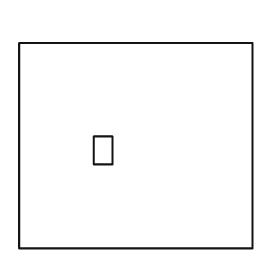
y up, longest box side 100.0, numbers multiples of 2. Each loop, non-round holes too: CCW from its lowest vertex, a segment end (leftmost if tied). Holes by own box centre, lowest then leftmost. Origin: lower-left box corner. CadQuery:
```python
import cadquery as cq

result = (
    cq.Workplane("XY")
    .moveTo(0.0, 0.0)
    .lineTo(100.0, 0.0)
    .lineTo(100.0, 88.0)
    .lineTo(0.0, 88.0)
    .close()
    .moveTo(32.0, 36.0)
    .lineTo(40.0, 36.0)
    .lineTo(40.0, 48.0)
    .lineTo(32.0, 48.0)
    .close()
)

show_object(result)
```